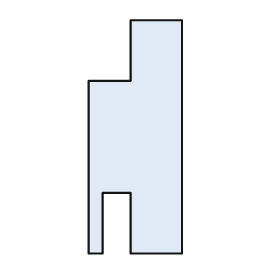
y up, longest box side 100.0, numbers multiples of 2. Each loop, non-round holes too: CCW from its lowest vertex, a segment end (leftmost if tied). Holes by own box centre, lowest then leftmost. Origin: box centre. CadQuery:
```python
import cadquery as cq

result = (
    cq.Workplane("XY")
    .moveTo(-20.0, -50.0)
    .lineTo(-14.0, -50.0)
    .lineTo(-14.0, -24.0)
    .lineTo(-2.0, -24.0)
    .lineTo(-2.0, -50.0)
    .lineTo(20.0, -50.0)
    .lineTo(20.0, 50.0)
    .lineTo(-2.0, 50.0)
    .lineTo(-2.0, 24.0)
    .lineTo(-20.0, 24.0)
    .close()
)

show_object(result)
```